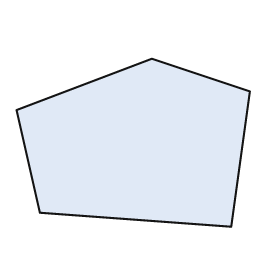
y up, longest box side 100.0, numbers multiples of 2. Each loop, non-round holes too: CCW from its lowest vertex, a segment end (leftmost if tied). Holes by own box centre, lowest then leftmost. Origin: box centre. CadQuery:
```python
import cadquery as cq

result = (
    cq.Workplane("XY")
    .moveTo(42.0, -36.0)
    .lineTo(50.0, 22.0)
    .lineTo(8.0, 36.0)
    .lineTo(-50.0, 14.0)
    .lineTo(-40.0, -30.0)
    .close()
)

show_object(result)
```